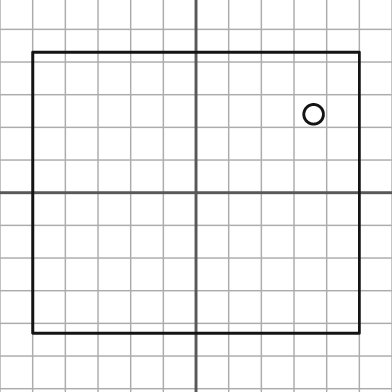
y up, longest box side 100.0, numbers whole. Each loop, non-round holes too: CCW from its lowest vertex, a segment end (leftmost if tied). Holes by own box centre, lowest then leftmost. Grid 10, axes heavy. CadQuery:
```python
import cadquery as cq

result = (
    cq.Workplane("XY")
    .moveTo(-50.0, -43.0)
    .lineTo(50.0, -43.0)
    .lineTo(50.0, 43.0)
    .lineTo(-50.0, 43.0)
    .close()
    .moveTo(36.0, 24.0)
    .circle(3.0)
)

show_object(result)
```